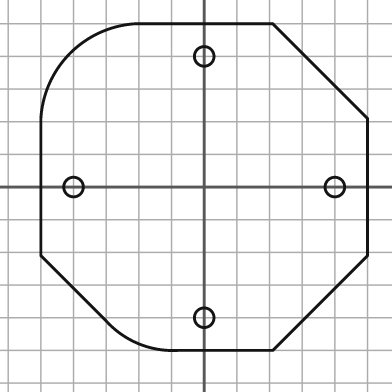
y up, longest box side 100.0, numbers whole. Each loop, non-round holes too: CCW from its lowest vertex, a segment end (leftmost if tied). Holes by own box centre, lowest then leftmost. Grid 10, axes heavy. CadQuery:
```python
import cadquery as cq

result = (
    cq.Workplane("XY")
    .moveTo(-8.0, -50.0)
    .lineTo(21.0, -50.0)
    .lineTo(50.0, -21.0)
    .lineTo(50.0, 21.0)
    .lineTo(21.0, 50.0)
    .lineTo(-21.0, 50.0)
    .threePointArc((-41.0, 41.0), (-50.0, 21.0))
    .lineTo(-50.0, -21.0)
    .lineTo(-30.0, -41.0)
    .threePointArc((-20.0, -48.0), (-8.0, -50.0))
    .close()
    .moveTo(0.0, -40.0)
    .circle(3.0)
    .moveTo(-40.0, 0.0)
    .circle(3.0)
    .moveTo(40.0, 0.0)
    .circle(3.0)
    .moveTo(0.0, 40.0)
    .circle(3.0)
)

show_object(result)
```